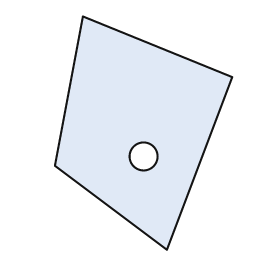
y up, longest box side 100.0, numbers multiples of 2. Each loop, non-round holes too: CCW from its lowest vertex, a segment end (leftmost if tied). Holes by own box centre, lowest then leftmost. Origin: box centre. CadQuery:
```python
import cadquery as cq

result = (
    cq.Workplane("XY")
    .moveTo(10.0, -50.0)
    .lineTo(38.0, 24.0)
    .lineTo(-26.0, 50.0)
    .lineTo(-38.0, -14.0)
    .close()
    .moveTo(0.0, -10.0)
    .circle(6.0)
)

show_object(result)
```